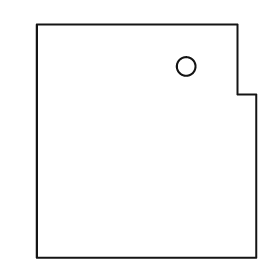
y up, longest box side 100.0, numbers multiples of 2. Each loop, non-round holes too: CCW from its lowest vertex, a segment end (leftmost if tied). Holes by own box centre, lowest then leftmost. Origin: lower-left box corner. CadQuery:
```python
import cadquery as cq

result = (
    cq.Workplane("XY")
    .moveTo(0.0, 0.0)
    .lineTo(94.0, 0.0)
    .lineTo(94.0, 70.0)
    .lineTo(86.0, 70.0)
    .lineTo(86.0, 100.0)
    .lineTo(0.0, 100.0)
    .close()
    .moveTo(64.0, 82.0)
    .circle(4.0)
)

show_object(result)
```